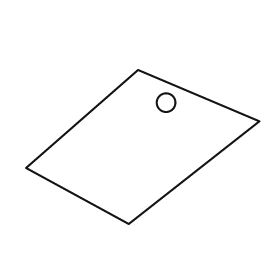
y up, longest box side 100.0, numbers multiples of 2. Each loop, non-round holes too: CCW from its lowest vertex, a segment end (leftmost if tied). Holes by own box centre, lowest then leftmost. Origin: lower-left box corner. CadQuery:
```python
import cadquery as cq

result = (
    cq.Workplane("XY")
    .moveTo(44.0, 0.0)
    .lineTo(100.0, 44.0)
    .lineTo(48.0, 66.0)
    .lineTo(0.0, 24.0)
    .close()
    .moveTo(60.0, 52.0)
    .circle(4.0)
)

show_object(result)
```